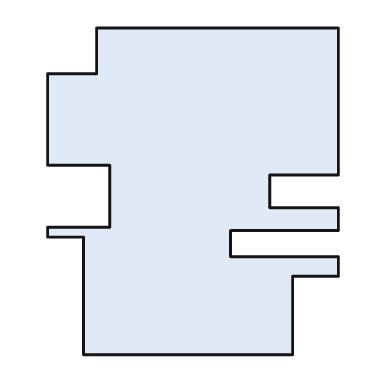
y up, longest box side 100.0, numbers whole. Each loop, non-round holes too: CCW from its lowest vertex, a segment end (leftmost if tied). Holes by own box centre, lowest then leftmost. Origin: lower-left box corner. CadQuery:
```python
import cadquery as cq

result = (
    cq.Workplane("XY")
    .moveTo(11.0, 0.0)
    .lineTo(75.0, 0.0)
    .lineTo(75.0, 24.0)
    .lineTo(89.0, 24.0)
    .lineTo(89.0, 30.0)
    .lineTo(56.0, 30.0)
    .lineTo(56.0, 38.0)
    .lineTo(89.0, 38.0)
    .lineTo(89.0, 45.0)
    .lineTo(68.0, 45.0)
    .lineTo(68.0, 55.0)
    .lineTo(89.0, 55.0)
    .lineTo(89.0, 100.0)
    .lineTo(15.0, 100.0)
    .lineTo(15.0, 86.0)
    .lineTo(0.0, 86.0)
    .lineTo(0.0, 58.0)
    .lineTo(19.0, 58.0)
    .lineTo(19.0, 39.0)
    .lineTo(0.0, 39.0)
    .lineTo(0.0, 36.0)
    .lineTo(11.0, 36.0)
    .close()
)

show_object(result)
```